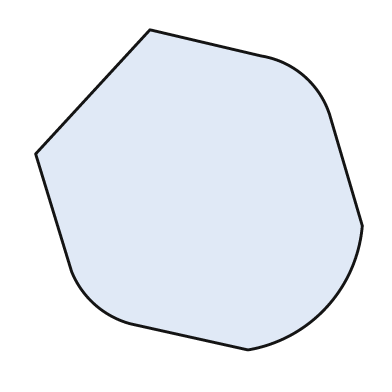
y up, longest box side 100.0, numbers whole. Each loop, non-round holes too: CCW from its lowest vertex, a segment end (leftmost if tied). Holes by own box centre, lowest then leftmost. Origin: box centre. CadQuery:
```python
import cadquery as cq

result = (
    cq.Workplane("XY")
    .moveTo(15.0, -49.0)
    .threePointArc((39.0, -36.0), (50.0, -11.0))
    .lineTo(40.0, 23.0)
    .threePointArc((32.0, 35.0), (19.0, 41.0))
    .lineTo(-15.0, 49.0)
    .lineTo(-50.0, 11.0)
    .lineTo(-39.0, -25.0)
    .threePointArc((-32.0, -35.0), (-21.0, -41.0))
    .close()
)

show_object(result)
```